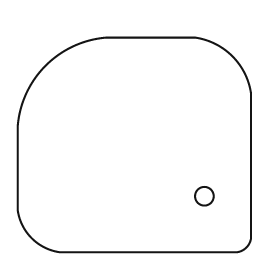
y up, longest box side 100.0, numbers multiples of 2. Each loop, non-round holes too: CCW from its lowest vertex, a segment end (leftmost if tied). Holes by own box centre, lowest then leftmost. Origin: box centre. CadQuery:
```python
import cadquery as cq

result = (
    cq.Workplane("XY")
    .moveTo(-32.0, -46.0)
    .lineTo(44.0, -46.0)
    .threePointArc((48.0, -44.0), (50.0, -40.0))
    .lineTo(50.0, 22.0)
    .threePointArc((42.0, 38.0), (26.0, 46.0))
    .lineTo(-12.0, 46.0)
    .threePointArc((-38.0, 34.0), (-50.0, 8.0))
    .lineTo(-50.0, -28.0)
    .threePointArc((-44.0, -40.0), (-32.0, -46.0))
    .close()
    .moveTo(30.0, -22.0)
    .circle(4.0)
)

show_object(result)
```